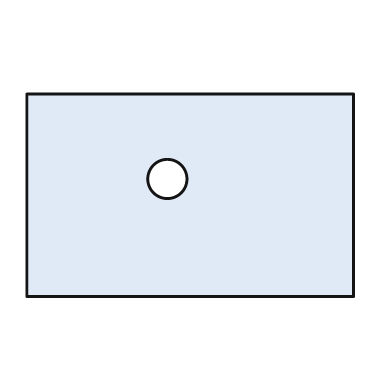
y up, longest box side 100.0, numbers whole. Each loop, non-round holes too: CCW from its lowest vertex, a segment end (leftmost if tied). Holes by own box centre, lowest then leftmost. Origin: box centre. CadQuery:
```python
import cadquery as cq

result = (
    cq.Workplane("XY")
    .moveTo(-50.0, -31.0)
    .lineTo(50.0, -31.0)
    .lineTo(50.0, 31.0)
    .lineTo(-50.0, 31.0)
    .close()
    .moveTo(-7.0, 5.0)
    .circle(6.0)
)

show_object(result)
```